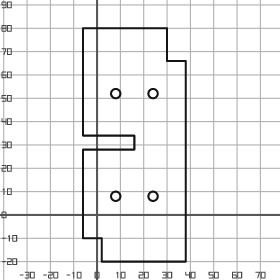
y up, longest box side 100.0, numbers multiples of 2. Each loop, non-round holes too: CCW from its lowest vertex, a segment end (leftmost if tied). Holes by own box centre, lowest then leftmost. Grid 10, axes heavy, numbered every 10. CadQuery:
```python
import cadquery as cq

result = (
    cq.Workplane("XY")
    .moveTo(2.0, -20.0)
    .lineTo(38.0, -20.0)
    .lineTo(38.0, 66.0)
    .lineTo(30.0, 66.0)
    .lineTo(30.0, 80.0)
    .lineTo(-6.0, 80.0)
    .lineTo(-6.0, 34.0)
    .lineTo(16.0, 34.0)
    .lineTo(16.0, 28.0)
    .lineTo(-6.0, 28.0)
    .lineTo(-6.0, -10.0)
    .lineTo(2.0, -10.0)
    .close()
    .moveTo(8.0, 8.0)
    .circle(2.0)
    .moveTo(24.0, 8.0)
    .circle(2.0)
    .moveTo(8.0, 52.0)
    .circle(2.0)
    .moveTo(24.0, 52.0)
    .circle(2.0)
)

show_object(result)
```